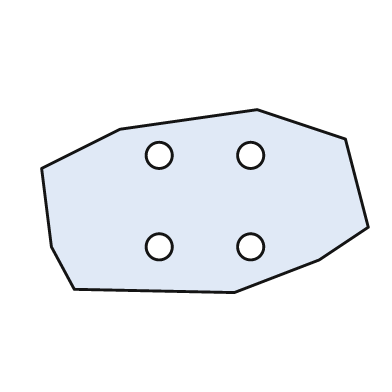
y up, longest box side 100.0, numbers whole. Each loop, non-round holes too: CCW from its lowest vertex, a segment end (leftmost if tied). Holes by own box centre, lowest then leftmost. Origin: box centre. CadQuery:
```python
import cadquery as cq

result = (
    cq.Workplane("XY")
    .moveTo(9.0, -28.0)
    .lineTo(35.0, -18.0)
    .lineTo(50.0, -8.0)
    .lineTo(43.0, 19.0)
    .lineTo(16.0, 28.0)
    .lineTo(-26.0, 22.0)
    .lineTo(-50.0, 10.0)
    .lineTo(-47.0, -14.0)
    .lineTo(-40.0, -27.0)
    .close()
    .moveTo(-14.0, -14.0)
    .circle(4.0)
    .moveTo(14.0, -14.0)
    .circle(4.0)
    .moveTo(-14.0, 14.0)
    .circle(4.0)
    .moveTo(14.0, 14.0)
    .circle(4.0)
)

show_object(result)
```